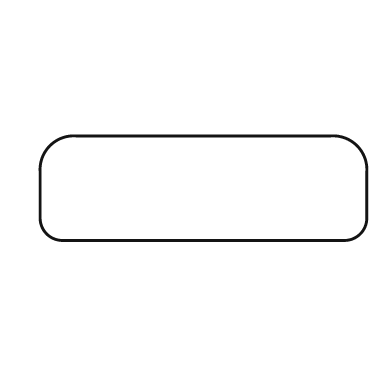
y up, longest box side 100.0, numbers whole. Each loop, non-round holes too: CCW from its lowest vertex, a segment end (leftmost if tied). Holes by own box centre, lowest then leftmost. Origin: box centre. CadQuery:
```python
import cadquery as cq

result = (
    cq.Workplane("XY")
    .moveTo(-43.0, -16.0)
    .lineTo(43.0, -16.0)
    .threePointArc((48.0, -14.0), (50.0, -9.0))
    .lineTo(50.0, 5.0)
    .threePointArc((47.0, 13.0), (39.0, 16.0))
    .lineTo(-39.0, 16.0)
    .threePointArc((-47.0, 13.0), (-50.0, 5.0))
    .lineTo(-50.0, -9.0)
    .threePointArc((-48.0, -14.0), (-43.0, -16.0))
    .close()
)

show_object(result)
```